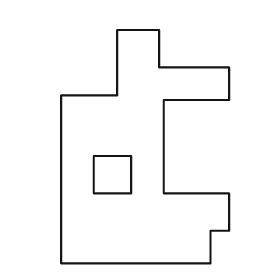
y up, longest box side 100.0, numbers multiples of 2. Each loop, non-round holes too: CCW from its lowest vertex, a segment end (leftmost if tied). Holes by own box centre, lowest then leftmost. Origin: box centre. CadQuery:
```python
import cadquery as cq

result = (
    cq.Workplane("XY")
    .moveTo(-36.0, -50.0)
    .lineTo(28.0, -50.0)
    .lineTo(28.0, -36.0)
    .lineTo(36.0, -36.0)
    .lineTo(36.0, -20.0)
    .lineTo(8.0, -20.0)
    .lineTo(8.0, 20.0)
    .lineTo(36.0, 20.0)
    .lineTo(36.0, 34.0)
    .lineTo(6.0, 34.0)
    .lineTo(6.0, 50.0)
    .lineTo(-12.0, 50.0)
    .lineTo(-12.0, 22.0)
    .lineTo(-36.0, 22.0)
    .close()
    .moveTo(-22.0, -20.0)
    .lineTo(-6.0, -20.0)
    .lineTo(-6.0, -4.0)
    .lineTo(-22.0, -4.0)
    .close()
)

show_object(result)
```